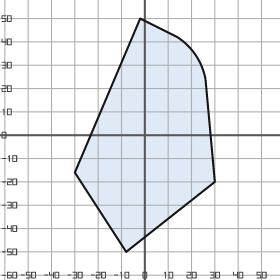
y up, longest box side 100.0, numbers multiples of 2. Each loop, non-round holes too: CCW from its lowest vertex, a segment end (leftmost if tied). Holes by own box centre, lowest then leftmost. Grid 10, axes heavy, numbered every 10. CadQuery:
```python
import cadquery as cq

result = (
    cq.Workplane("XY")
    .moveTo(-8.0, -50.0)
    .lineTo(30.0, -20.0)
    .lineTo(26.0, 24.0)
    .threePointArc((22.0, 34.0), (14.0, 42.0))
    .lineTo(-2.0, 50.0)
    .lineTo(-30.0, -16.0)
    .close()
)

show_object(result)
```